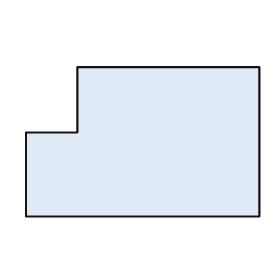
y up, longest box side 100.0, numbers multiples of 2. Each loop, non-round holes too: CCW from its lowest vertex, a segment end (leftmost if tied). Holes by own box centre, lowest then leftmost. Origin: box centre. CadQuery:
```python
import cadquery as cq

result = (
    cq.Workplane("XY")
    .moveTo(-50.0, -32.0)
    .lineTo(50.0, -32.0)
    .lineTo(50.0, 32.0)
    .lineTo(-28.0, 32.0)
    .lineTo(-28.0, 4.0)
    .lineTo(-50.0, 4.0)
    .close()
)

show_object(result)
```